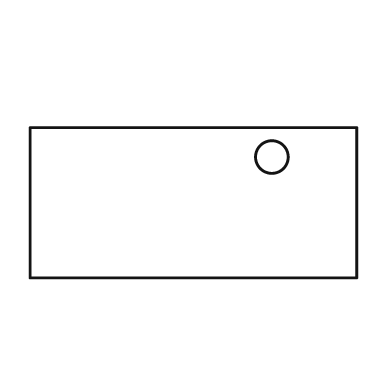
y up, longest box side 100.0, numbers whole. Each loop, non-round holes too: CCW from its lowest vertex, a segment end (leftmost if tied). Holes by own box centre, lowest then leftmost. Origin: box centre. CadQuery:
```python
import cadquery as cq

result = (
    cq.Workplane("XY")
    .moveTo(-50.0, -23.0)
    .lineTo(50.0, -23.0)
    .lineTo(50.0, 23.0)
    .lineTo(-50.0, 23.0)
    .close()
    .moveTo(24.0, 14.0)
    .circle(5.0)
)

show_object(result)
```